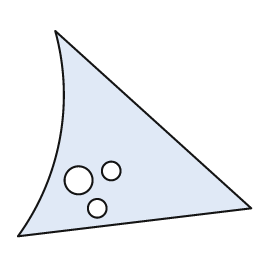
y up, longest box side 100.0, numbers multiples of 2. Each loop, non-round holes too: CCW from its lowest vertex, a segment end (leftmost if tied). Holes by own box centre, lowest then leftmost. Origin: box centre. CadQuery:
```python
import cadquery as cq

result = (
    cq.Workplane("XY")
    .moveTo(-50.0, -44.0)
    .lineTo(50.0, -32.0)
    .lineTo(-34.0, 44.0)
    .threePointArc((-32.0, -2.0), (-50.0, -44.0))
    .close()
    .moveTo(-16.0, -32.0)
    .circle(4.0)
    .moveTo(-24.0, -20.0)
    .circle(6.0)
    .moveTo(-10.0, -16.0)
    .circle(4.0)
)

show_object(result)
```